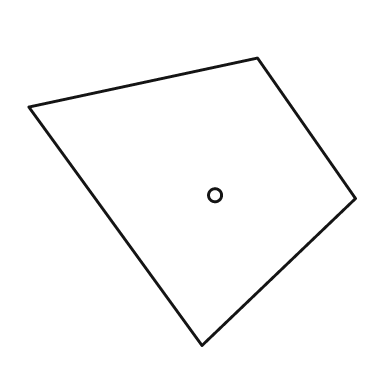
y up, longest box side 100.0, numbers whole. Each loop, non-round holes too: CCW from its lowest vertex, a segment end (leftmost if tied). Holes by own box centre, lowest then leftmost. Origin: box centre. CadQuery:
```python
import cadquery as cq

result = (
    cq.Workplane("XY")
    .moveTo(3.0, -44.0)
    .lineTo(50.0, 1.0)
    .lineTo(20.0, 44.0)
    .lineTo(-50.0, 29.0)
    .close()
    .moveTo(7.0, 2.0)
    .circle(2.0)
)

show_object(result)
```